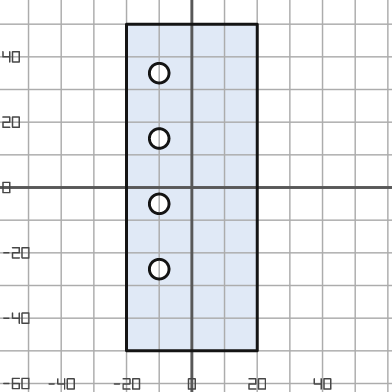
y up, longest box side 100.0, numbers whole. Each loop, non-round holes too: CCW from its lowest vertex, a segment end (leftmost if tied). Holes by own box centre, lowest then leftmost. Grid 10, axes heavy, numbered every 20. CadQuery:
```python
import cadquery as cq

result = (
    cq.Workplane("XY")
    .moveTo(-20.0, -50.0)
    .lineTo(20.0, -50.0)
    .lineTo(20.0, 50.0)
    .lineTo(-20.0, 50.0)
    .close()
    .moveTo(-10.0, -25.0)
    .circle(3.0)
    .moveTo(-10.0, -5.0)
    .circle(3.0)
    .moveTo(-10.0, 15.0)
    .circle(3.0)
    .moveTo(-10.0, 35.0)
    .circle(3.0)
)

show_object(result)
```